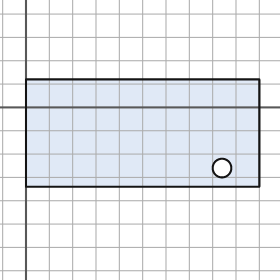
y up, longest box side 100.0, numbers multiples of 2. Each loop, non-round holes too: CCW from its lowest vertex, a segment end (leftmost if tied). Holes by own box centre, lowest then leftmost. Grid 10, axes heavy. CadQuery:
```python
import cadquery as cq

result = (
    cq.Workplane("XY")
    .moveTo(0.0, -34.0)
    .lineTo(100.0, -34.0)
    .lineTo(100.0, 12.0)
    .lineTo(0.0, 12.0)
    .close()
    .moveTo(84.0, -26.0)
    .circle(4.0)
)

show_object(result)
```